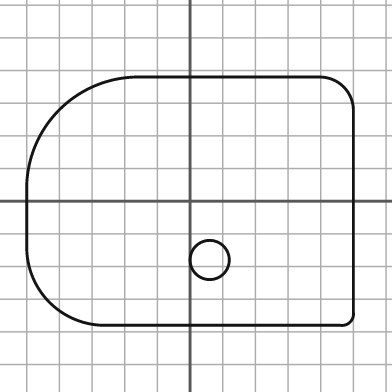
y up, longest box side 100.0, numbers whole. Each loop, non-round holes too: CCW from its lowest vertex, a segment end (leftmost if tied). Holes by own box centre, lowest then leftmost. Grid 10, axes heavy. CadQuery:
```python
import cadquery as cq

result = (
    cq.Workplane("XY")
    .moveTo(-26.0, -38.0)
    .lineTo(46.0, -38.0)
    .threePointArc((49.0, -37.0), (50.0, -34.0))
    .lineTo(50.0, 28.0)
    .threePointArc((47.0, 35.0), (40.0, 38.0))
    .lineTo(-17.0, 38.0)
    .threePointArc((-40.0, 28.0), (-50.0, 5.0))
    .lineTo(-50.0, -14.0)
    .threePointArc((-43.0, -31.0), (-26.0, -38.0))
    .close()
    .moveTo(6.0, -18.0)
    .circle(6.0)
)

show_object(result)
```